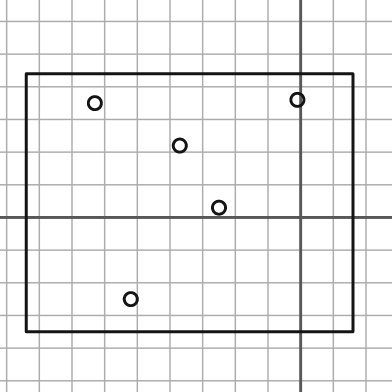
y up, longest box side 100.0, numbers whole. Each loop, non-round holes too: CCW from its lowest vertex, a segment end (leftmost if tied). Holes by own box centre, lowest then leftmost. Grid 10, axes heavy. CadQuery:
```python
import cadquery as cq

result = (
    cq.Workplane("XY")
    .moveTo(-84.0, -35.0)
    .lineTo(16.0, -35.0)
    .lineTo(16.0, 44.0)
    .lineTo(-84.0, 44.0)
    .close()
    .moveTo(-52.0, -25.0)
    .circle(2.0)
    .moveTo(-25.0, 3.0)
    .circle(2.0)
    .moveTo(-37.0, 22.0)
    .circle(2.0)
    .moveTo(-63.0, 35.0)
    .circle(2.0)
    .moveTo(-1.0, 36.0)
    .circle(2.0)
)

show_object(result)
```